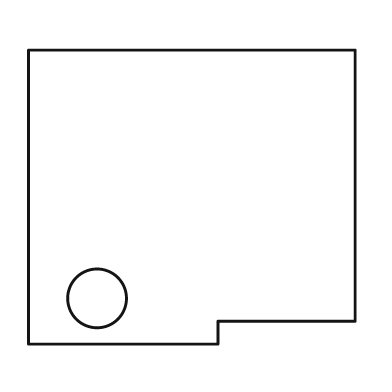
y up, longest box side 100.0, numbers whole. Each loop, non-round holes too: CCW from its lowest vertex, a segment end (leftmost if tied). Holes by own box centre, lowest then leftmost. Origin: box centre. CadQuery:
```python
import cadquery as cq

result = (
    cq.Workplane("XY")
    .moveTo(-50.0, -45.0)
    .lineTo(8.0, -45.0)
    .lineTo(8.0, -38.0)
    .lineTo(50.0, -38.0)
    .lineTo(50.0, 45.0)
    .lineTo(-50.0, 45.0)
    .close()
    .moveTo(-29.0, -31.0)
    .circle(9.0)
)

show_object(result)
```